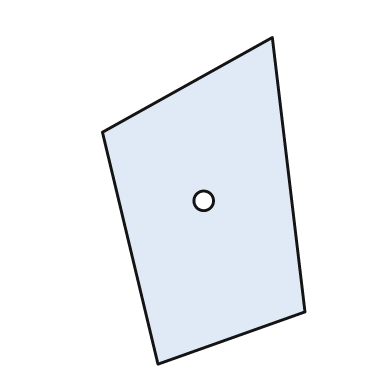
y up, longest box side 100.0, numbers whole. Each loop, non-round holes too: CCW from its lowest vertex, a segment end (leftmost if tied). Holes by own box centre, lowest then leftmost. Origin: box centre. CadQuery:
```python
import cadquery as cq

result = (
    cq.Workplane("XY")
    .moveTo(-14.0, -50.0)
    .lineTo(31.0, -34.0)
    .lineTo(21.0, 50.0)
    .lineTo(-31.0, 21.0)
    .close()
    .moveTo(0.0, 0.0)
    .circle(3.0)
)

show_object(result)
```